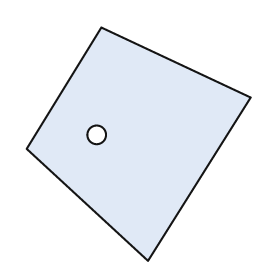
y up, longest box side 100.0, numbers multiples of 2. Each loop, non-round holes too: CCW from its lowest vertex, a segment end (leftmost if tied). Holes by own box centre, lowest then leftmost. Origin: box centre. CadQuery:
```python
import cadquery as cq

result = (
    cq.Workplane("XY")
    .moveTo(4.0, -50.0)
    .lineTo(48.0, 20.0)
    .lineTo(-16.0, 50.0)
    .lineTo(-48.0, -2.0)
    .close()
    .moveTo(-18.0, 4.0)
    .circle(4.0)
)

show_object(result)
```